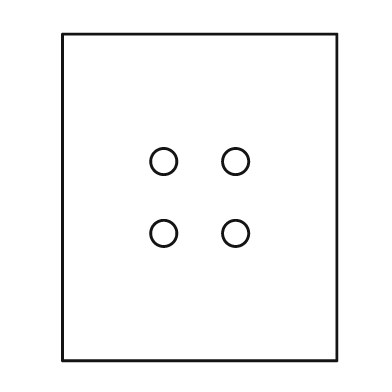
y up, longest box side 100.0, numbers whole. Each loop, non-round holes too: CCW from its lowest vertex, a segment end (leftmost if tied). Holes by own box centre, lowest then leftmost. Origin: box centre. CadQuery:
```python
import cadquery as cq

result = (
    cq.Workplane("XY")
    .moveTo(-42.0, -50.0)
    .lineTo(42.0, -50.0)
    .lineTo(42.0, 50.0)
    .lineTo(-42.0, 50.0)
    .close()
    .moveTo(-11.0, -11.0)
    .circle(4.0)
    .moveTo(11.0, -11.0)
    .circle(4.0)
    .moveTo(-11.0, 11.0)
    .circle(4.0)
    .moveTo(11.0, 11.0)
    .circle(4.0)
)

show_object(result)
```